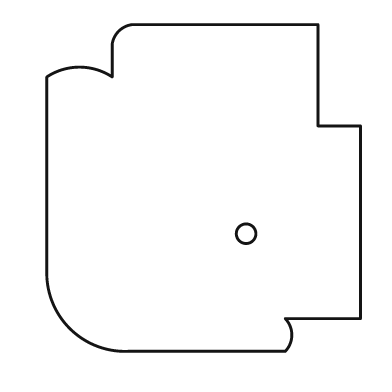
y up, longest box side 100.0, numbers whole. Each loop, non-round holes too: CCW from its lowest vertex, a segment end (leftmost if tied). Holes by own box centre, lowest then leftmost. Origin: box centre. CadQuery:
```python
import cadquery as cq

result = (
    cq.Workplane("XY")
    .moveTo(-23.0, -50.0)
    .lineTo(25.0, -50.0)
    .threePointArc((27.0, -45.0), (25.0, -40.0))
    .lineTo(48.0, -40.0)
    .lineTo(48.0, 19.0)
    .lineTo(35.0, 19.0)
    .lineTo(35.0, 50.0)
    .lineTo(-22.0, 50.0)
    .threePointArc((-26.0, 48.0), (-28.0, 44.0))
    .lineTo(-28.0, 34.0)
    .threePointArc((-38.0, 37.0), (-48.0, 34.0))
    .lineTo(-48.0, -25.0)
    .threePointArc((-41.0, -43.0), (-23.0, -50.0))
    .close()
    .moveTo(13.0, -14.0)
    .circle(3.0)
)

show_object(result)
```